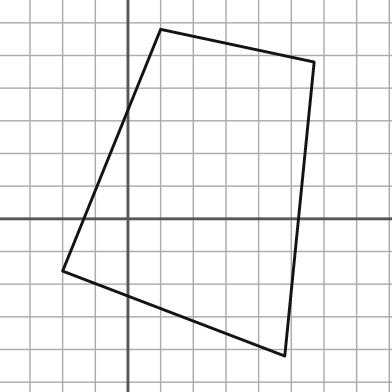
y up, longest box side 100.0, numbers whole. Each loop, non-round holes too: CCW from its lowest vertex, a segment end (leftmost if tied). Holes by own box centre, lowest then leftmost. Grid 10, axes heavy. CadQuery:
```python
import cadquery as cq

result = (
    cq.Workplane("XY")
    .moveTo(48.0, -42.0)
    .lineTo(57.0, 48.0)
    .lineTo(10.0, 58.0)
    .lineTo(-20.0, -16.0)
    .close()
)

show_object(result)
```